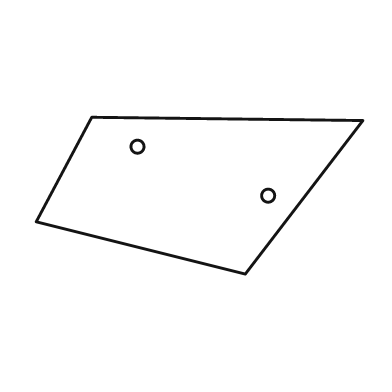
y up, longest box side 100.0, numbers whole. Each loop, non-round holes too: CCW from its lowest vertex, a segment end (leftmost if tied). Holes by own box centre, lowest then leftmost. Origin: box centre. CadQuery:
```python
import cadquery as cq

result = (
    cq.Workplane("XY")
    .moveTo(14.0, -24.0)
    .lineTo(50.0, 23.0)
    .lineTo(-33.0, 24.0)
    .lineTo(-50.0, -8.0)
    .close()
    .moveTo(21.0, 0.0)
    .circle(2.0)
    .moveTo(-19.0, 15.0)
    .circle(2.0)
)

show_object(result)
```